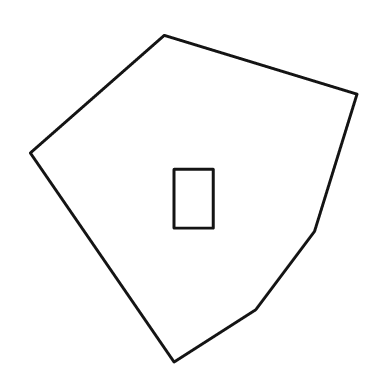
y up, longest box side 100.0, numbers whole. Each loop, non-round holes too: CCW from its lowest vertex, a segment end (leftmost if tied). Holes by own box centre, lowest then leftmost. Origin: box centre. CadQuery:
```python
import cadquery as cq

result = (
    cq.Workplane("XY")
    .moveTo(-6.0, -50.0)
    .lineTo(19.0, -34.0)
    .lineTo(37.0, -10.0)
    .lineTo(50.0, 32.0)
    .lineTo(-9.0, 50.0)
    .lineTo(-50.0, 14.0)
    .close()
    .moveTo(-6.0, -9.0)
    .lineTo(6.0, -9.0)
    .lineTo(6.0, 9.0)
    .lineTo(-6.0, 9.0)
    .close()
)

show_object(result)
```